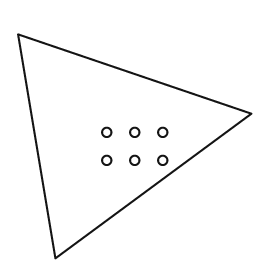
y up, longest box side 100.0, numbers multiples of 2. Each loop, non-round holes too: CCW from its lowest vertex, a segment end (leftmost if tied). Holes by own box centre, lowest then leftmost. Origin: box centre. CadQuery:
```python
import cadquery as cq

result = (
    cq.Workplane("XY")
    .moveTo(-34.0, -48.0)
    .lineTo(50.0, 14.0)
    .lineTo(-50.0, 48.0)
    .close()
    .moveTo(-12.0, -6.0)
    .circle(2.0)
    .moveTo(0.0, -6.0)
    .circle(2.0)
    .moveTo(12.0, -6.0)
    .circle(2.0)
    .moveTo(-12.0, 6.0)
    .circle(2.0)
    .moveTo(0.0, 6.0)
    .circle(2.0)
    .moveTo(12.0, 6.0)
    .circle(2.0)
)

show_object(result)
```